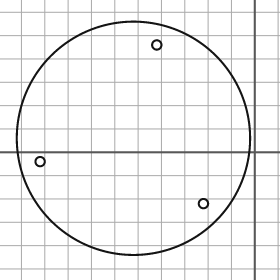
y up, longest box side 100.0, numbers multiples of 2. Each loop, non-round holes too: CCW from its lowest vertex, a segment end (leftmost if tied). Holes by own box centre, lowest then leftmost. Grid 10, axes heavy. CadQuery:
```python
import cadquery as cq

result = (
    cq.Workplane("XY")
    .moveTo(-52.0, 6.0)
    .circle(50.0)
    .moveTo(-22.0, -22.0)
    .circle(2.0)
    .moveTo(-92.0, -4.0)
    .circle(2.0)
    .moveTo(-42.0, 46.0)
    .circle(2.0)
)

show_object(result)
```